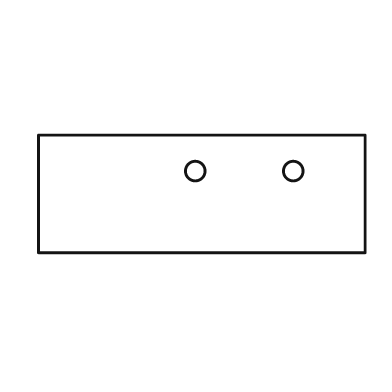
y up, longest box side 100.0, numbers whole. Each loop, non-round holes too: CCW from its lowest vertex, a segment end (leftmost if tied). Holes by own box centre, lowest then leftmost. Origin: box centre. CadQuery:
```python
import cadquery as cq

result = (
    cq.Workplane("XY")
    .moveTo(-50.0, -18.0)
    .lineTo(50.0, -18.0)
    .lineTo(50.0, 18.0)
    .lineTo(-50.0, 18.0)
    .close()
    .moveTo(-2.0, 7.0)
    .circle(3.0)
    .moveTo(28.0, 7.0)
    .circle(3.0)
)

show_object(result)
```